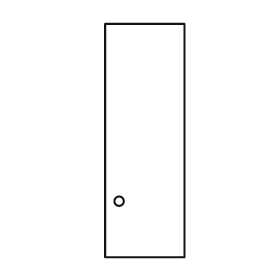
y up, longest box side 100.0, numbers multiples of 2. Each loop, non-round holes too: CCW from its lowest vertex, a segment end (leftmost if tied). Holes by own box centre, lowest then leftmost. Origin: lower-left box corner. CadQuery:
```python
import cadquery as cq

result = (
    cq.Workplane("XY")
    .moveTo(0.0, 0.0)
    .lineTo(34.0, 0.0)
    .lineTo(34.0, 100.0)
    .lineTo(0.0, 100.0)
    .close()
    .moveTo(6.0, 24.0)
    .circle(2.0)
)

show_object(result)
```